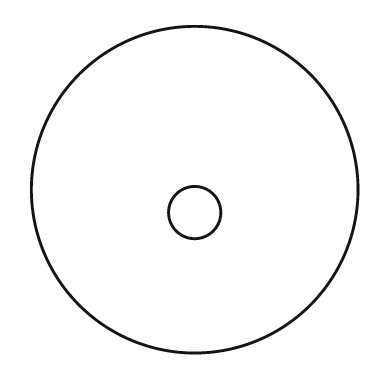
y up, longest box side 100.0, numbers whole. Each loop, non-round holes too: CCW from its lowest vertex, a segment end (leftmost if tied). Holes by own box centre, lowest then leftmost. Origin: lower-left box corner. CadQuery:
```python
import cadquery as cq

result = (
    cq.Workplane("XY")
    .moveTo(50.0, 50.0)
    .circle(50.0)
    .moveTo(50.0, 43.0)
    .circle(8.0)
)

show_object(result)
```